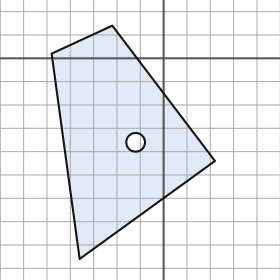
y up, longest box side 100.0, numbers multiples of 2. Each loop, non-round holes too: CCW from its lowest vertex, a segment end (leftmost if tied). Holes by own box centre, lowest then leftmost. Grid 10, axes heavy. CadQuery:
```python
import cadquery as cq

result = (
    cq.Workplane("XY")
    .moveTo(-36.0, -86.0)
    .lineTo(22.0, -44.0)
    .lineTo(-22.0, 14.0)
    .lineTo(-48.0, 2.0)
    .close()
    .moveTo(-12.0, -36.0)
    .circle(4.0)
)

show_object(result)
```